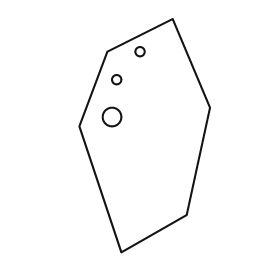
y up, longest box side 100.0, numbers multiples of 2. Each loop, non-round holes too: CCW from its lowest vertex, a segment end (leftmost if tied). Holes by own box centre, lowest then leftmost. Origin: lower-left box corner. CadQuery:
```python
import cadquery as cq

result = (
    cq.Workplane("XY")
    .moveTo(18.0, 0.0)
    .lineTo(46.0, 16.0)
    .lineTo(56.0, 62.0)
    .lineTo(40.0, 100.0)
    .lineTo(12.0, 86.0)
    .lineTo(0.0, 54.0)
    .close()
    .moveTo(14.0, 58.0)
    .circle(4.0)
    .moveTo(16.0, 74.0)
    .circle(2.0)
    .moveTo(26.0, 86.0)
    .circle(2.0)
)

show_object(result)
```